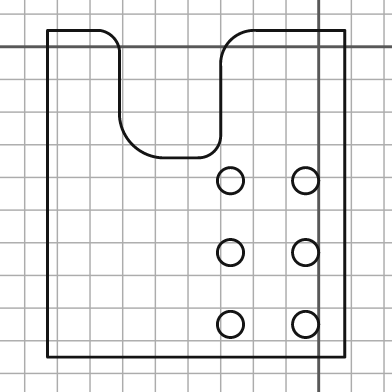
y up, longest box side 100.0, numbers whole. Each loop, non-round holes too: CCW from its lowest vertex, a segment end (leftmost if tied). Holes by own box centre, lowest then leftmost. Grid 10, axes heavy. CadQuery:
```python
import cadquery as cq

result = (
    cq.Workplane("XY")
    .moveTo(-83.0, -95.0)
    .lineTo(8.0, -95.0)
    .lineTo(8.0, 5.0)
    .lineTo(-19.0, 5.0)
    .threePointArc((-27.0, 2.0), (-30.0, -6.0))
    .lineTo(-30.0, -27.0)
    .threePointArc((-32.0, -32.0), (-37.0, -34.0))
    .lineTo(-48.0, -34.0)
    .threePointArc((-57.0, -30.0), (-61.0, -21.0))
    .lineTo(-61.0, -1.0)
    .threePointArc((-63.0, 3.0), (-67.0, 5.0))
    .lineTo(-83.0, 5.0)
    .close()
    .moveTo(-27.0, -85.0)
    .circle(4.0)
    .moveTo(-4.0, -85.0)
    .circle(4.0)
    .moveTo(-27.0, -63.0)
    .circle(4.0)
    .moveTo(-4.0, -63.0)
    .circle(4.0)
    .moveTo(-27.0, -41.0)
    .circle(4.0)
    .moveTo(-4.0, -41.0)
    .circle(4.0)
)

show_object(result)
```